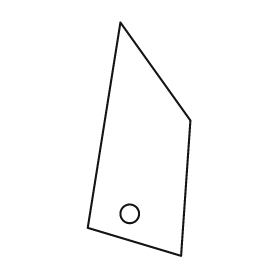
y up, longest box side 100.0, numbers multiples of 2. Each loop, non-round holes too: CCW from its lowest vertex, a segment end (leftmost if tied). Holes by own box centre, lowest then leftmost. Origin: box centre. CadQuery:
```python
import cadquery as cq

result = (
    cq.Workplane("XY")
    .moveTo(18.0, -50.0)
    .lineTo(22.0, 8.0)
    .lineTo(-8.0, 50.0)
    .lineTo(-22.0, -38.0)
    .close()
    .moveTo(-4.0, -32.0)
    .circle(4.0)
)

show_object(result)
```